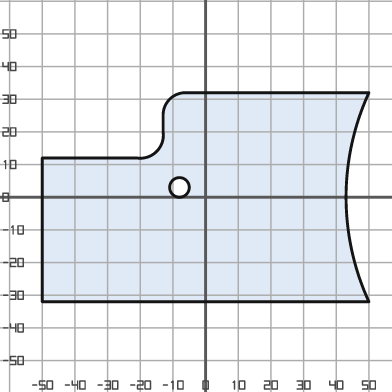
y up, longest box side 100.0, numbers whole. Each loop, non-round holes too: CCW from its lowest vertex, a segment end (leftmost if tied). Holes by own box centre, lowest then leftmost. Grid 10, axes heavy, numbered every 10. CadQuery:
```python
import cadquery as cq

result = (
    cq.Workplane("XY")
    .moveTo(-50.0, -32.0)
    .lineTo(50.0, -32.0)
    .threePointArc((43.0, 0.0), (50.0, 32.0))
    .lineTo(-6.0, 32.0)
    .threePointArc((-11.0, 30.0), (-13.0, 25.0))
    .lineTo(-13.0, 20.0)
    .threePointArc((-15.0, 14.0), (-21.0, 12.0))
    .lineTo(-50.0, 12.0)
    .close()
    .moveTo(-8.0, 3.0)
    .circle(3.0)
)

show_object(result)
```